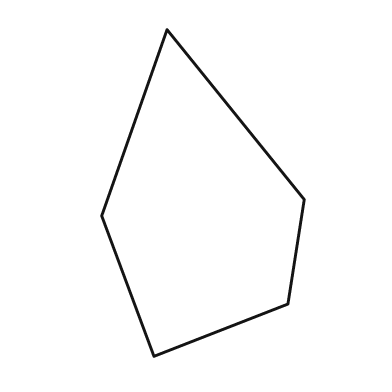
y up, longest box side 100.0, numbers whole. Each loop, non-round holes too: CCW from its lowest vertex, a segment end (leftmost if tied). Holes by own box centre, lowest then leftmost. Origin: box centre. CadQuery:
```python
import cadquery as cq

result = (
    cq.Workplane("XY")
    .moveTo(-15.0, -50.0)
    .lineTo(26.0, -34.0)
    .lineTo(31.0, -2.0)
    .lineTo(-11.0, 50.0)
    .lineTo(-31.0, -7.0)
    .close()
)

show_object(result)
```